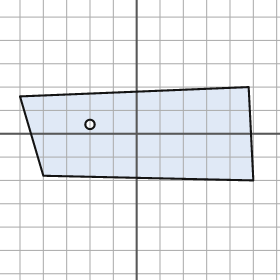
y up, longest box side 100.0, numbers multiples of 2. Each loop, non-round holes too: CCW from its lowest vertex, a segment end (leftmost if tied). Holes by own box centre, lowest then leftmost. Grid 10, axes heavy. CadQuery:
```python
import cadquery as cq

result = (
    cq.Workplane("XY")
    .moveTo(50.0, -20.0)
    .lineTo(48.0, 20.0)
    .lineTo(-50.0, 16.0)
    .lineTo(-40.0, -18.0)
    .close()
    .moveTo(-20.0, 4.0)
    .circle(2.0)
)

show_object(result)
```